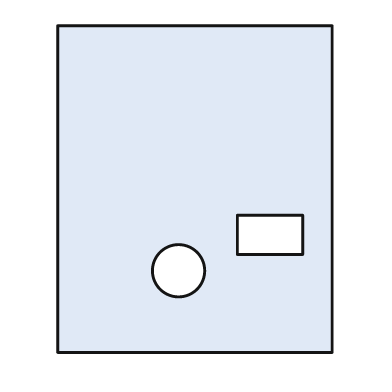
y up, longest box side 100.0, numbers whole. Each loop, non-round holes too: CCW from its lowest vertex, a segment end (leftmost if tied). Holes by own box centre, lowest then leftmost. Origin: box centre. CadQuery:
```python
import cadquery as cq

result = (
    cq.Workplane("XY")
    .moveTo(-42.0, -50.0)
    .lineTo(42.0, -50.0)
    .lineTo(42.0, 50.0)
    .lineTo(-42.0, 50.0)
    .close()
    .moveTo(-5.0, -25.0)
    .circle(8.0)
    .moveTo(13.0, -20.0)
    .lineTo(33.0, -20.0)
    .lineTo(33.0, -8.0)
    .lineTo(13.0, -8.0)
    .close()
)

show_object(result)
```